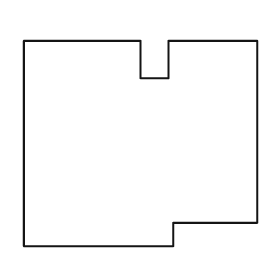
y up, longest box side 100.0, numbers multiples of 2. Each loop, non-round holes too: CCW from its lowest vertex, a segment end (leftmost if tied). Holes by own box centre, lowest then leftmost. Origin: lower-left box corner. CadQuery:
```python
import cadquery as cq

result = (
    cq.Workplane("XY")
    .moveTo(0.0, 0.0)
    .lineTo(64.0, 0.0)
    .lineTo(64.0, 10.0)
    .lineTo(100.0, 10.0)
    .lineTo(100.0, 88.0)
    .lineTo(62.0, 88.0)
    .lineTo(62.0, 72.0)
    .lineTo(50.0, 72.0)
    .lineTo(50.0, 88.0)
    .lineTo(0.0, 88.0)
    .close()
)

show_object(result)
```